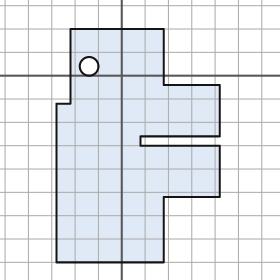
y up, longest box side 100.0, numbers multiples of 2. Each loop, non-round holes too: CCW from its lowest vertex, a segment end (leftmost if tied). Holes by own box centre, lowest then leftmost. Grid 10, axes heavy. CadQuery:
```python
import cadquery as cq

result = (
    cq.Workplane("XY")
    .moveTo(-28.0, -80.0)
    .lineTo(18.0, -80.0)
    .lineTo(18.0, -52.0)
    .lineTo(42.0, -52.0)
    .lineTo(42.0, -30.0)
    .lineTo(8.0, -30.0)
    .lineTo(8.0, -26.0)
    .lineTo(42.0, -26.0)
    .lineTo(42.0, -4.0)
    .lineTo(18.0, -4.0)
    .lineTo(18.0, 20.0)
    .lineTo(-22.0, 20.0)
    .lineTo(-22.0, -12.0)
    .lineTo(-28.0, -12.0)
    .close()
    .moveTo(-14.0, 4.0)
    .circle(4.0)
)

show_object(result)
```